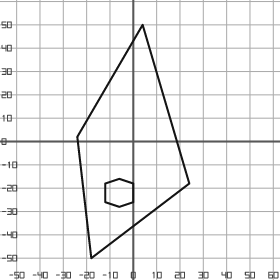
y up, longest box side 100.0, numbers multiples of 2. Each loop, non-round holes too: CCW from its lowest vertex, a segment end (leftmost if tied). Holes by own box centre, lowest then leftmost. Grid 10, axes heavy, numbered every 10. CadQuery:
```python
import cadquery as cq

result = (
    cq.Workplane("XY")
    .moveTo(-18.0, -50.0)
    .lineTo(24.0, -18.0)
    .lineTo(4.0, 50.0)
    .lineTo(-24.0, 2.0)
    .close()
    .moveTo(-6.0, -28.0)
    .lineTo(0.0, -26.0)
    .lineTo(0.0, -18.0)
    .lineTo(-6.0, -16.0)
    .lineTo(-12.0, -18.0)
    .lineTo(-12.0, -26.0)
    .close()
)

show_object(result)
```